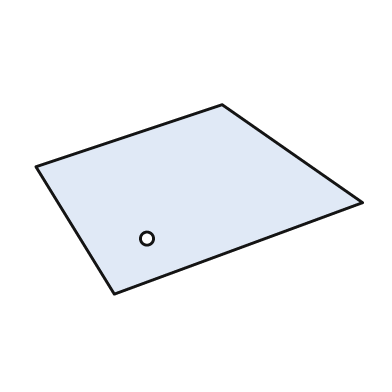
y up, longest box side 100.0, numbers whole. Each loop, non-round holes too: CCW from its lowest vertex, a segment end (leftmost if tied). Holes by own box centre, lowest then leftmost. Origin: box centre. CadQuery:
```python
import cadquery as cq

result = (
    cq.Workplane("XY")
    .moveTo(-26.0, -29.0)
    .lineTo(50.0, -1.0)
    .lineTo(7.0, 29.0)
    .lineTo(-50.0, 10.0)
    .close()
    .moveTo(-16.0, -12.0)
    .circle(2.0)
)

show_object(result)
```